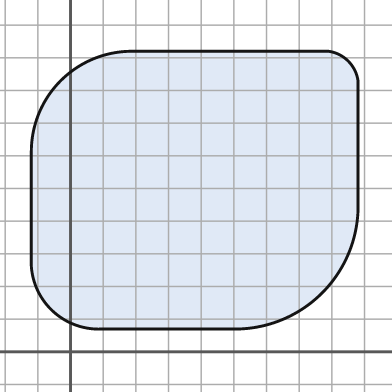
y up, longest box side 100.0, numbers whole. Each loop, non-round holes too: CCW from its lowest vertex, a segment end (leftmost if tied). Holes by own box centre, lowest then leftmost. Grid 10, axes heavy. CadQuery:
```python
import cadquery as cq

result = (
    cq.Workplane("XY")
    .moveTo(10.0, 7.0)
    .lineTo(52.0, 7.0)
    .threePointArc((77.0, 18.0), (88.0, 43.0))
    .lineTo(88.0, 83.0)
    .threePointArc((85.0, 89.0), (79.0, 92.0))
    .lineTo(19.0, 92.0)
    .threePointArc((-3.0, 83.0), (-12.0, 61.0))
    .lineTo(-12.0, 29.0)
    .threePointArc((-6.0, 13.0), (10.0, 7.0))
    .close()
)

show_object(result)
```